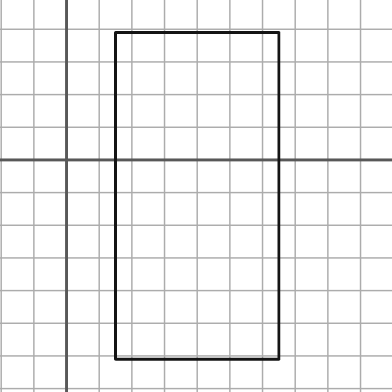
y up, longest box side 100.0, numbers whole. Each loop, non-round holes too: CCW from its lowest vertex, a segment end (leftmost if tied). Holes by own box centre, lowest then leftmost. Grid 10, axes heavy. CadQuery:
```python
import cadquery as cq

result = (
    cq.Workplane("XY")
    .moveTo(15.0, -61.0)
    .lineTo(65.0, -61.0)
    .lineTo(65.0, 39.0)
    .lineTo(15.0, 39.0)
    .close()
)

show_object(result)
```